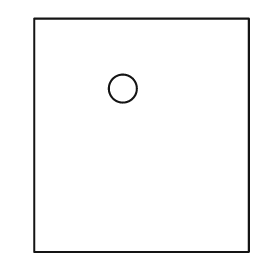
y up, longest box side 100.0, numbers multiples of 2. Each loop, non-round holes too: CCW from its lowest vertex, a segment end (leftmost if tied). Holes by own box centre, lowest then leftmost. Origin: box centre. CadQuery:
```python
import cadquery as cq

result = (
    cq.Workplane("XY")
    .moveTo(-46.0, -50.0)
    .lineTo(46.0, -50.0)
    .lineTo(46.0, 50.0)
    .lineTo(-46.0, 50.0)
    .close()
    .moveTo(-8.0, 20.0)
    .circle(6.0)
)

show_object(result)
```